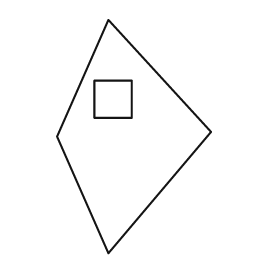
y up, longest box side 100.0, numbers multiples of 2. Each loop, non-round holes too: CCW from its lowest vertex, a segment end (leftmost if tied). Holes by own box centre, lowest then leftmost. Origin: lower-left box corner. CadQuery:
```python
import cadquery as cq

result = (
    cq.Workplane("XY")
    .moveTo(22.0, 0.0)
    .lineTo(66.0, 52.0)
    .lineTo(22.0, 100.0)
    .lineTo(0.0, 50.0)
    .close()
    .moveTo(16.0, 58.0)
    .lineTo(32.0, 58.0)
    .lineTo(32.0, 74.0)
    .lineTo(16.0, 74.0)
    .close()
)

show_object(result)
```